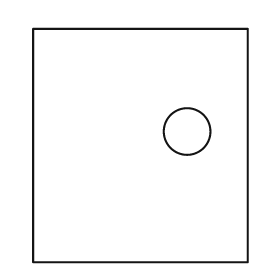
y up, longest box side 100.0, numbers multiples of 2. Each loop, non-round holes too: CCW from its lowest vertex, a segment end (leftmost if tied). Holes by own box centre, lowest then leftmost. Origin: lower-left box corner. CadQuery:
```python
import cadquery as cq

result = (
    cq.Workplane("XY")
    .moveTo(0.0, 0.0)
    .lineTo(92.0, 0.0)
    .lineTo(92.0, 100.0)
    .lineTo(0.0, 100.0)
    .close()
    .moveTo(66.0, 56.0)
    .circle(10.0)
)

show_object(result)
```